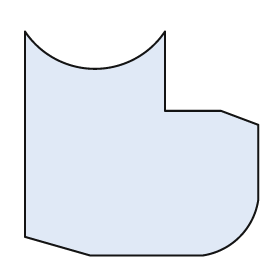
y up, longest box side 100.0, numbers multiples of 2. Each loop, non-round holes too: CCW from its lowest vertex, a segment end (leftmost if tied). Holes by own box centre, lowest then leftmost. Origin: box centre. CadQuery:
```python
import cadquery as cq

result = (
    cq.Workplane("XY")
    .moveTo(-22.0, -48.0)
    .lineTo(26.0, -48.0)
    .threePointArc((42.0, -40.0), (50.0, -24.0))
    .lineTo(50.0, 8.0)
    .lineTo(34.0, 14.0)
    .lineTo(10.0, 14.0)
    .lineTo(10.0, 48.0)
    .threePointArc((-20.0, 32.0), (-50.0, 48.0))
    .lineTo(-50.0, -40.0)
    .close()
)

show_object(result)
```